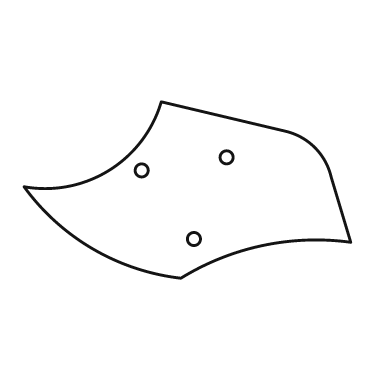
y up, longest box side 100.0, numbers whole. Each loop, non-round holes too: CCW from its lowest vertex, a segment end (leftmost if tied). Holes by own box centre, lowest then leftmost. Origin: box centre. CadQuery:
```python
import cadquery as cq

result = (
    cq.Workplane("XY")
    .moveTo(-2.0, -27.0)
    .threePointArc((23.0, -17.0), (50.0, -16.0))
    .lineTo(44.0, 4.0)
    .threePointArc((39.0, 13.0), (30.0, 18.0))
    .lineTo(-8.0, 27.0)
    .threePointArc((-24.0, 6.0), (-50.0, 1.0))
    .threePointArc((-29.0, -18.0), (-2.0, -27.0))
    .close()
    .moveTo(2.0, -15.0)
    .circle(2.0)
    .moveTo(-14.0, 6.0)
    .circle(2.0)
    .moveTo(12.0, 10.0)
    .circle(2.0)
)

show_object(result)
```